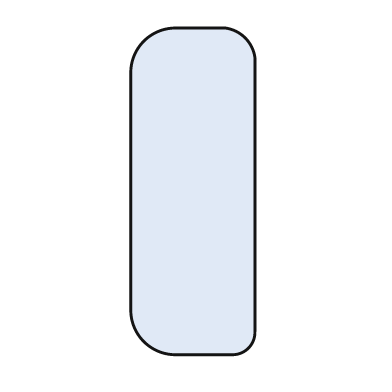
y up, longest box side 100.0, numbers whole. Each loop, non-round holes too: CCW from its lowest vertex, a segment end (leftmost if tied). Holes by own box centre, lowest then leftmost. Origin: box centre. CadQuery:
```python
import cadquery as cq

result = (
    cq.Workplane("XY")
    .moveTo(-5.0, -50.0)
    .lineTo(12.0, -50.0)
    .threePointArc((17.0, -48.0), (19.0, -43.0))
    .lineTo(19.0, 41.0)
    .threePointArc((16.0, 47.0), (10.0, 50.0))
    .lineTo(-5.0, 50.0)
    .threePointArc((-15.0, 46.0), (-19.0, 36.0))
    .lineTo(-19.0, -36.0)
    .threePointArc((-15.0, -46.0), (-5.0, -50.0))
    .close()
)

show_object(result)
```